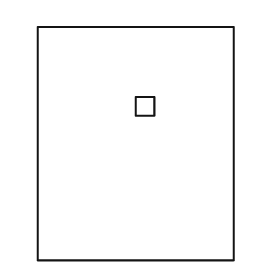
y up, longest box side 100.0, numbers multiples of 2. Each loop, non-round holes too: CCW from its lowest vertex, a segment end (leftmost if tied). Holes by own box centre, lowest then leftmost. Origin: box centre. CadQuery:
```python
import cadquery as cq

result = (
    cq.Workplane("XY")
    .moveTo(-42.0, -50.0)
    .lineTo(42.0, -50.0)
    .lineTo(42.0, 50.0)
    .lineTo(-42.0, 50.0)
    .close()
    .moveTo(0.0, 12.0)
    .lineTo(8.0, 12.0)
    .lineTo(8.0, 20.0)
    .lineTo(0.0, 20.0)
    .close()
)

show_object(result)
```